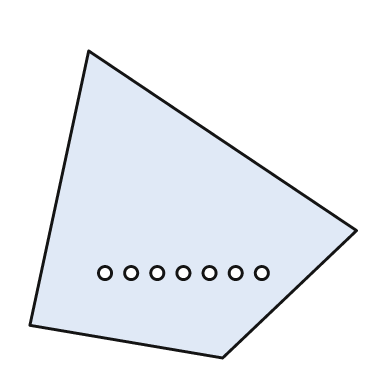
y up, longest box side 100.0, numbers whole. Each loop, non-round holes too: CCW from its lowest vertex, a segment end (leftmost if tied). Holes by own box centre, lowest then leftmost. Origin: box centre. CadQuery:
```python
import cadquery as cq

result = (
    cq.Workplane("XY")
    .moveTo(9.0, -47.0)
    .lineTo(50.0, -8.0)
    .lineTo(-32.0, 47.0)
    .lineTo(-50.0, -37.0)
    .close()
    .moveTo(-27.0, -21.0)
    .circle(2.0)
    .moveTo(-19.0, -21.0)
    .circle(2.0)
    .moveTo(-11.0, -21.0)
    .circle(2.0)
    .moveTo(-3.0, -21.0)
    .circle(2.0)
    .moveTo(5.0, -21.0)
    .circle(2.0)
    .moveTo(13.0, -21.0)
    .circle(2.0)
    .moveTo(21.0, -21.0)
    .circle(2.0)
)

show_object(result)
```